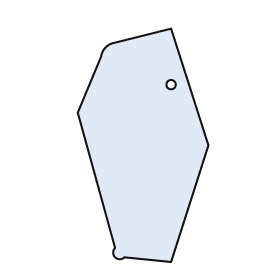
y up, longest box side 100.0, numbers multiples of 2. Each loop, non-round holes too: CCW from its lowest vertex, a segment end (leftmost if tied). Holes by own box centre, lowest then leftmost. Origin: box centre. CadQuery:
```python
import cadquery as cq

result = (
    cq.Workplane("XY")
    .moveTo(12.0, -50.0)
    .lineTo(28.0, 0.0)
    .lineTo(12.0, 50.0)
    .lineTo(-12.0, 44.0)
    .threePointArc((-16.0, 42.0), (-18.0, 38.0))
    .lineTo(-28.0, 14.0)
    .lineTo(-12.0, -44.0)
    .threePointArc((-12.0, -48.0), (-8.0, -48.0))
    .close()
    .moveTo(12.0, 26.0)
    .circle(2.0)
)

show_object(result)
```